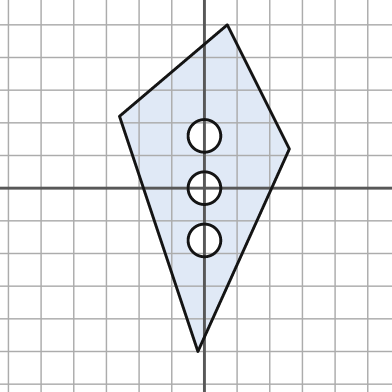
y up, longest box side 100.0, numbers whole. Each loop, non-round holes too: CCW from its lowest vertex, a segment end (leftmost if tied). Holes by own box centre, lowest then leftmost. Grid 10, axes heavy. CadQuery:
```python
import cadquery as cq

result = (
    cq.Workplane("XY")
    .moveTo(-2.0, -50.0)
    .lineTo(26.0, 12.0)
    .lineTo(7.0, 50.0)
    .lineTo(-26.0, 22.0)
    .close()
    .moveTo(0.0, -16.0)
    .circle(5.0)
    .moveTo(0.0, 0.0)
    .circle(5.0)
    .moveTo(0.0, 16.0)
    .circle(5.0)
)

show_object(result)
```